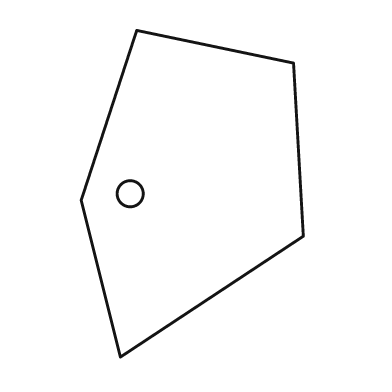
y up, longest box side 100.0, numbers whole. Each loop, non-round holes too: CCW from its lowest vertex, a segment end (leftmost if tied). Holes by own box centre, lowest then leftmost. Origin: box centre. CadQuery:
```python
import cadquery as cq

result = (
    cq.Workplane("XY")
    .moveTo(-22.0, -50.0)
    .lineTo(34.0, -13.0)
    .lineTo(31.0, 40.0)
    .lineTo(-17.0, 50.0)
    .lineTo(-34.0, -2.0)
    .close()
    .moveTo(-19.0, 0.0)
    .circle(4.0)
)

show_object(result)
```